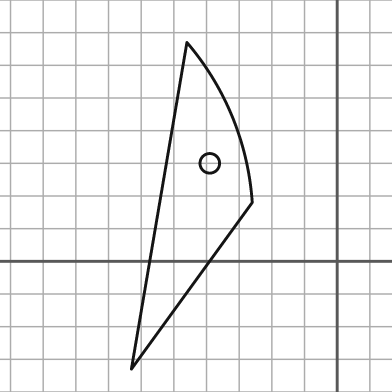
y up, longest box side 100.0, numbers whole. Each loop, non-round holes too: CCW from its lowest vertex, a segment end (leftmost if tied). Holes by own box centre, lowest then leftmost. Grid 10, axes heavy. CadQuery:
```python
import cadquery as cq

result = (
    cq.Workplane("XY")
    .moveTo(-63.0, -33.0)
    .lineTo(-26.0, 18.0)
    .threePointArc((-32.0, 44.0), (-46.0, 67.0))
    .close()
    .moveTo(-39.0, 30.0)
    .circle(3.0)
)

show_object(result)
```